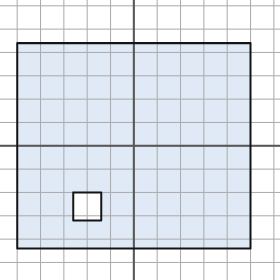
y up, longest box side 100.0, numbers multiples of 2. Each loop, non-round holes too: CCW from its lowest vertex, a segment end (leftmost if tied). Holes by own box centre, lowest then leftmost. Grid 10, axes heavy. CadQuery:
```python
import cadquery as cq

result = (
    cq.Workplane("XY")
    .moveTo(-50.0, -44.0)
    .lineTo(50.0, -44.0)
    .lineTo(50.0, 44.0)
    .lineTo(-50.0, 44.0)
    .close()
    .moveTo(-26.0, -32.0)
    .lineTo(-14.0, -32.0)
    .lineTo(-14.0, -20.0)
    .lineTo(-26.0, -20.0)
    .close()
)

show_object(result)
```